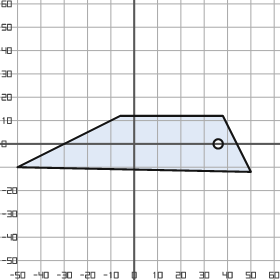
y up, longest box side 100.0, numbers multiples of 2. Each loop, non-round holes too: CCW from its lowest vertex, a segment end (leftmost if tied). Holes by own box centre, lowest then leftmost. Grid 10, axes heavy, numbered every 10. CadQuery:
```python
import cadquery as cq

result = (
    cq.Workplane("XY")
    .moveTo(50.0, -12.0)
    .lineTo(38.0, 12.0)
    .lineTo(-6.0, 12.0)
    .lineTo(-50.0, -10.0)
    .close()
    .moveTo(36.0, 0.0)
    .circle(2.0)
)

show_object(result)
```